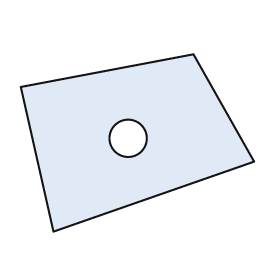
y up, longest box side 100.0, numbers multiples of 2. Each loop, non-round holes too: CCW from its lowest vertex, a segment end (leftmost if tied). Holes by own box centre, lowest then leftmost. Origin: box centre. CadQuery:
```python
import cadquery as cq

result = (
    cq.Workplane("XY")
    .moveTo(-36.0, -38.0)
    .lineTo(50.0, -8.0)
    .lineTo(24.0, 38.0)
    .lineTo(-50.0, 24.0)
    .close()
    .moveTo(-4.0, 2.0)
    .circle(8.0)
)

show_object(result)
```